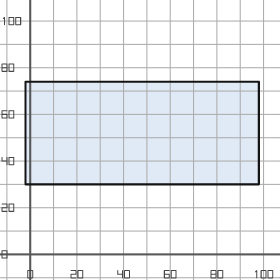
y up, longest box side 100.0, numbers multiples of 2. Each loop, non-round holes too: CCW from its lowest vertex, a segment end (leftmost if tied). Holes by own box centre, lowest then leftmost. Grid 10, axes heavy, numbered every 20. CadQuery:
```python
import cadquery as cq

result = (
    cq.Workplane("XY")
    .moveTo(-2.0, 30.0)
    .lineTo(98.0, 30.0)
    .lineTo(98.0, 74.0)
    .lineTo(-2.0, 74.0)
    .close()
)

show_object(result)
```